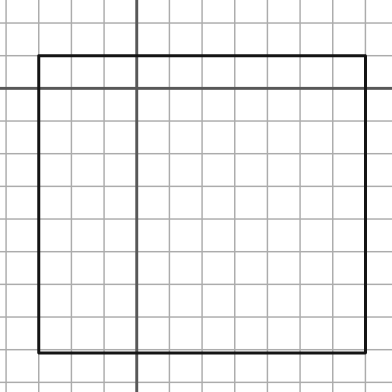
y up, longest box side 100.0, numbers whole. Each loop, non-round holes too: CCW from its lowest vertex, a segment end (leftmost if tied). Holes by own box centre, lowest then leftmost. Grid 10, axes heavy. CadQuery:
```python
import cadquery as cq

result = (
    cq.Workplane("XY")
    .moveTo(-30.0, -81.0)
    .lineTo(70.0, -81.0)
    .lineTo(70.0, 10.0)
    .lineTo(-30.0, 10.0)
    .close()
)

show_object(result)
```